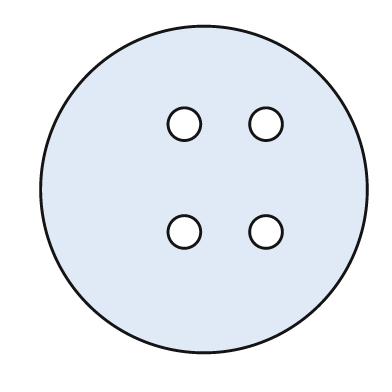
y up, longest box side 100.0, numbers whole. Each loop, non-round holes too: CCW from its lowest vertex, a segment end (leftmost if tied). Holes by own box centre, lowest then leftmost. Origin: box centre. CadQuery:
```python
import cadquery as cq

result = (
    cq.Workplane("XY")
    .moveTo(0.0, 0.0)
    .circle(50.0)
    .moveTo(-6.0, -13.0)
    .circle(5.0)
    .moveTo(19.0, -13.0)
    .circle(5.0)
    .moveTo(-6.0, 20.0)
    .circle(5.0)
    .moveTo(19.0, 20.0)
    .circle(5.0)
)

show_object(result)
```